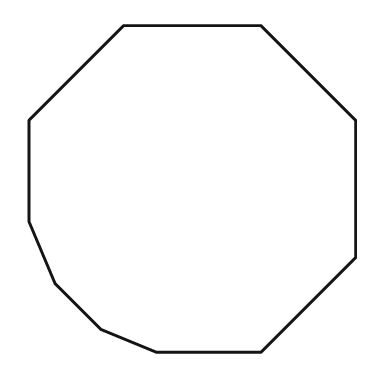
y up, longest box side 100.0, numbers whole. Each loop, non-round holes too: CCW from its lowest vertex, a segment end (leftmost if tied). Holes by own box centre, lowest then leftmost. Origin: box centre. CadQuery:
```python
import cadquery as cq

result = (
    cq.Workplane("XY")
    .moveTo(-11.0, -50.0)
    .lineTo(21.0, -50.0)
    .lineTo(50.0, -21.0)
    .lineTo(50.0, 21.0)
    .lineTo(21.0, 50.0)
    .lineTo(-21.0, 50.0)
    .lineTo(-50.0, 21.0)
    .lineTo(-50.0, -10.0)
    .lineTo(-42.0, -29.0)
    .lineTo(-28.0, -43.0)
    .close()
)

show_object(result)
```